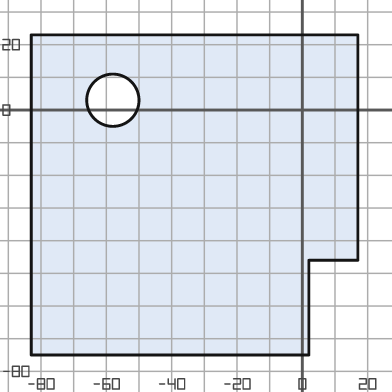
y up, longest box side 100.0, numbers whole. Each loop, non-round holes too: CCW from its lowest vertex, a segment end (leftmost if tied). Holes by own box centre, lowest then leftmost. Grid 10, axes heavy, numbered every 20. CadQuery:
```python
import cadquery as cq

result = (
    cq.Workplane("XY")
    .moveTo(-83.0, -75.0)
    .lineTo(2.0, -75.0)
    .lineTo(2.0, -46.0)
    .lineTo(17.0, -46.0)
    .lineTo(17.0, 23.0)
    .lineTo(-83.0, 23.0)
    .close()
    .moveTo(-58.0, 3.0)
    .circle(8.0)
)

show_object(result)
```